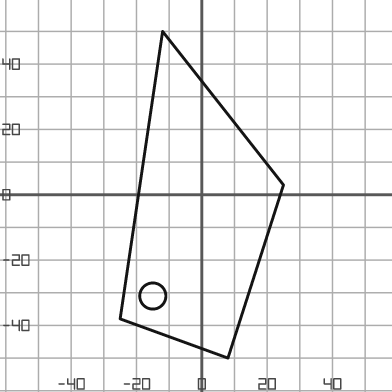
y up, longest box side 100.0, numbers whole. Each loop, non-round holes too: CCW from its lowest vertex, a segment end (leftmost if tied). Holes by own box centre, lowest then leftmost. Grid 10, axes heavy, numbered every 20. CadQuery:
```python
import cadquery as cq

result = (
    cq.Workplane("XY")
    .moveTo(8.0, -50.0)
    .lineTo(25.0, 3.0)
    .lineTo(-12.0, 50.0)
    .lineTo(-25.0, -38.0)
    .close()
    .moveTo(-15.0, -31.0)
    .circle(4.0)
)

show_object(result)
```